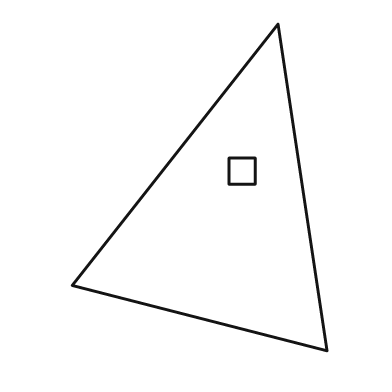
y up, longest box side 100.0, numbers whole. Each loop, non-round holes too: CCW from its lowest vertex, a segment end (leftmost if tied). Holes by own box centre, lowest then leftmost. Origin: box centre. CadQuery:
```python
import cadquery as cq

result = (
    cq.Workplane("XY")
    .moveTo(39.0, -50.0)
    .lineTo(24.0, 50.0)
    .lineTo(-39.0, -30.0)
    .close()
    .moveTo(9.0, 1.0)
    .lineTo(17.0, 1.0)
    .lineTo(17.0, 9.0)
    .lineTo(9.0, 9.0)
    .close()
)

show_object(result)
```